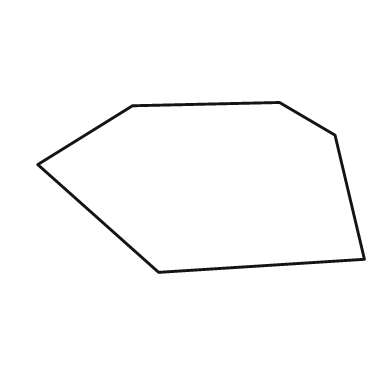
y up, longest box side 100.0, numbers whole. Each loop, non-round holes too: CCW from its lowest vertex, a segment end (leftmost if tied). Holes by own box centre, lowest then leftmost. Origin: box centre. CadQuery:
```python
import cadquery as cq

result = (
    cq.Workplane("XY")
    .moveTo(-13.0, -26.0)
    .lineTo(50.0, -22.0)
    .lineTo(41.0, 16.0)
    .lineTo(24.0, 26.0)
    .lineTo(-21.0, 25.0)
    .lineTo(-50.0, 7.0)
    .close()
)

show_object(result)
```